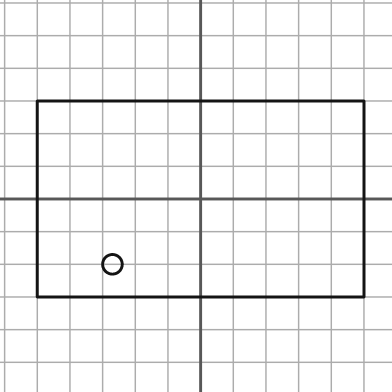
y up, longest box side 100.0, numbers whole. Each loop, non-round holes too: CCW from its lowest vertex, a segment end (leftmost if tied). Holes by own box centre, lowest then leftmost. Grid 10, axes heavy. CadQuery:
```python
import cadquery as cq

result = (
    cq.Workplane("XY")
    .moveTo(-50.0, -30.0)
    .lineTo(50.0, -30.0)
    .lineTo(50.0, 30.0)
    .lineTo(-50.0, 30.0)
    .close()
    .moveTo(-27.0, -20.0)
    .circle(3.0)
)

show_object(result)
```